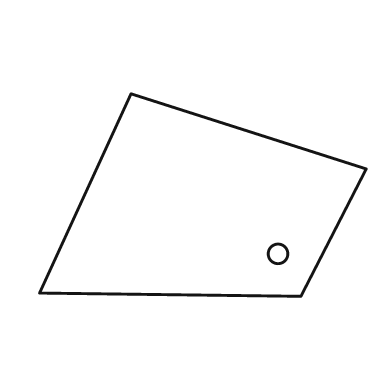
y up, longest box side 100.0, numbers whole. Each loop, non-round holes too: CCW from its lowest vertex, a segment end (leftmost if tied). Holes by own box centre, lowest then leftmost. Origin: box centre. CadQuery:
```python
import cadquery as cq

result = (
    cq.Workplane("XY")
    .moveTo(30.0, -31.0)
    .lineTo(50.0, 8.0)
    .lineTo(-22.0, 31.0)
    .lineTo(-50.0, -30.0)
    .close()
    .moveTo(23.0, -18.0)
    .circle(3.0)
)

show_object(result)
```